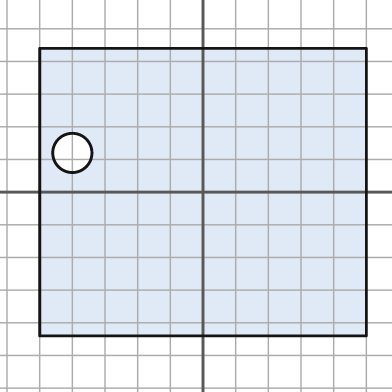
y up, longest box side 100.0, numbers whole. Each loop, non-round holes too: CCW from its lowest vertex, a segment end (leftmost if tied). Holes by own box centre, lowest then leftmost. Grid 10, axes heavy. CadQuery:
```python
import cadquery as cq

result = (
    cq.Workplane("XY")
    .moveTo(-50.0, -44.0)
    .lineTo(50.0, -44.0)
    .lineTo(50.0, 44.0)
    .lineTo(-50.0, 44.0)
    .close()
    .moveTo(-40.0, 12.0)
    .circle(6.0)
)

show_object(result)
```